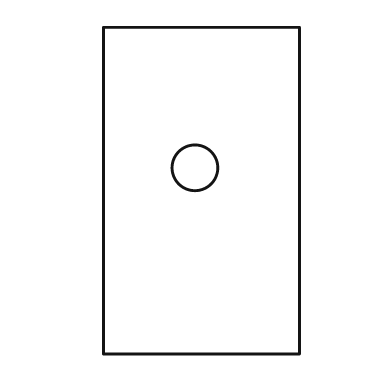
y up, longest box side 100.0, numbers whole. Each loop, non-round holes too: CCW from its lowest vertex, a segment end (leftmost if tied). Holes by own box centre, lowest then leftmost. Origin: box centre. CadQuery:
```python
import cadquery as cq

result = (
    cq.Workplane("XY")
    .moveTo(-30.0, -50.0)
    .lineTo(30.0, -50.0)
    .lineTo(30.0, 50.0)
    .lineTo(-30.0, 50.0)
    .close()
    .moveTo(-2.0, 7.0)
    .circle(7.0)
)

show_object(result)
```